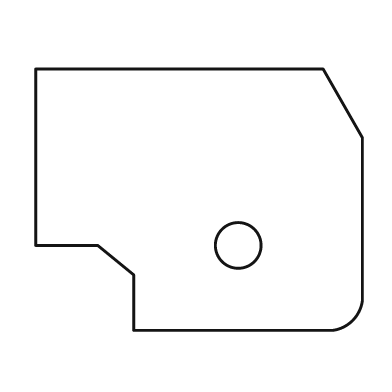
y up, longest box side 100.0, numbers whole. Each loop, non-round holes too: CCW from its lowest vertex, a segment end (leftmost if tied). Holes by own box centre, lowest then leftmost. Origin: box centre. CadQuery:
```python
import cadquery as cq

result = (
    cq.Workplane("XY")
    .moveTo(-20.0, -40.0)
    .lineTo(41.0, -40.0)
    .threePointArc((47.0, -37.0), (50.0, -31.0))
    .lineTo(50.0, 19.0)
    .lineTo(38.0, 40.0)
    .lineTo(-50.0, 40.0)
    .lineTo(-50.0, -14.0)
    .lineTo(-31.0, -14.0)
    .lineTo(-20.0, -23.0)
    .close()
    .moveTo(12.0, -14.0)
    .circle(7.0)
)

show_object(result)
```